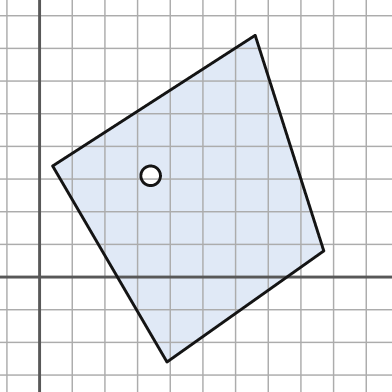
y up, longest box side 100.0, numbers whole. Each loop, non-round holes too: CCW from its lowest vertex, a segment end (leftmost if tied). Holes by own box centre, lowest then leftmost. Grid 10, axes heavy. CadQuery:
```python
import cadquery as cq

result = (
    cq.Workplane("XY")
    .moveTo(39.0, -26.0)
    .lineTo(87.0, 8.0)
    .lineTo(66.0, 74.0)
    .lineTo(4.0, 34.0)
    .close()
    .moveTo(34.0, 31.0)
    .circle(3.0)
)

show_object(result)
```